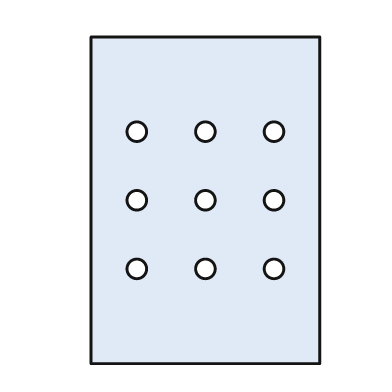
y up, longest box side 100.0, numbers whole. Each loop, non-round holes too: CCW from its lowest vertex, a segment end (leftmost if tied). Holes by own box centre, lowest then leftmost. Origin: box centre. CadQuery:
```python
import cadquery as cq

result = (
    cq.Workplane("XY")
    .moveTo(-35.0, -50.0)
    .lineTo(35.0, -50.0)
    .lineTo(35.0, 50.0)
    .lineTo(-35.0, 50.0)
    .close()
    .moveTo(-21.0, -21.0)
    .circle(3.0)
    .moveTo(0.0, -21.0)
    .circle(3.0)
    .moveTo(21.0, -21.0)
    .circle(3.0)
    .moveTo(-21.0, 0.0)
    .circle(3.0)
    .moveTo(0.0, 0.0)
    .circle(3.0)
    .moveTo(21.0, 0.0)
    .circle(3.0)
    .moveTo(-21.0, 21.0)
    .circle(3.0)
    .moveTo(0.0, 21.0)
    .circle(3.0)
    .moveTo(21.0, 21.0)
    .circle(3.0)
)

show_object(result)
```